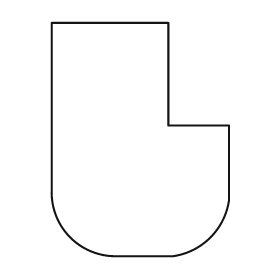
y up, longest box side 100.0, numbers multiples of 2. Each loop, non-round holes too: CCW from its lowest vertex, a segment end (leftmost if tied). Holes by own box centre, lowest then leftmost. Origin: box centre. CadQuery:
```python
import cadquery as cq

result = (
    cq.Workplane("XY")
    .moveTo(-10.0, -50.0)
    .lineTo(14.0, -50.0)
    .threePointArc((30.0, -42.0), (38.0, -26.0))
    .lineTo(38.0, 6.0)
    .lineTo(12.0, 6.0)
    .lineTo(12.0, 50.0)
    .lineTo(-38.0, 50.0)
    .lineTo(-38.0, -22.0)
    .threePointArc((-30.0, -42.0), (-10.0, -50.0))
    .close()
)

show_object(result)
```